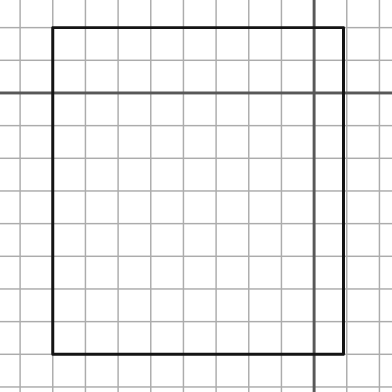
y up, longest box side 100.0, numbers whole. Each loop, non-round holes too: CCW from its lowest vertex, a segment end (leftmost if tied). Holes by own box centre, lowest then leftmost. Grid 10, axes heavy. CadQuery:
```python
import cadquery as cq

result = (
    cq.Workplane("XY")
    .moveTo(-80.0, -80.0)
    .lineTo(9.0, -80.0)
    .lineTo(9.0, 20.0)
    .lineTo(-80.0, 20.0)
    .close()
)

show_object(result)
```